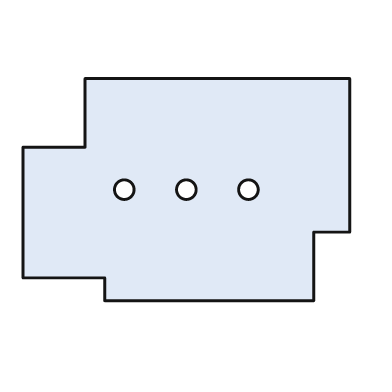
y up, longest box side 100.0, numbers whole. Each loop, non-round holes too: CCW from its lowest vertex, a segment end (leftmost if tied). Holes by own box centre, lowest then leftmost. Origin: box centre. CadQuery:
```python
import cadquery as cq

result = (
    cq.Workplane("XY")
    .moveTo(-25.0, -34.0)
    .lineTo(39.0, -34.0)
    .lineTo(39.0, -13.0)
    .lineTo(50.0, -13.0)
    .lineTo(50.0, 34.0)
    .lineTo(-31.0, 34.0)
    .lineTo(-31.0, 13.0)
    .lineTo(-50.0, 13.0)
    .lineTo(-50.0, -27.0)
    .lineTo(-25.0, -27.0)
    .close()
    .moveTo(-19.0, 0.0)
    .circle(3.0)
    .moveTo(0.0, 0.0)
    .circle(3.0)
    .moveTo(19.0, 0.0)
    .circle(3.0)
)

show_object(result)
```